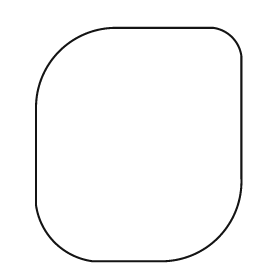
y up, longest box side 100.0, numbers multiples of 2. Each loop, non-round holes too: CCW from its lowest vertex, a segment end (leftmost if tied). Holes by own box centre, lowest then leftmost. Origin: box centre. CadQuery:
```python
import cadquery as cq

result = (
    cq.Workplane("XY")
    .moveTo(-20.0, -50.0)
    .lineTo(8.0, -50.0)
    .threePointArc((34.0, -40.0), (44.0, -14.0))
    .lineTo(44.0, 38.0)
    .threePointArc((40.0, 46.0), (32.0, 50.0))
    .lineTo(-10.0, 50.0)
    .threePointArc((-34.0, 40.0), (-44.0, 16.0))
    .lineTo(-44.0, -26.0)
    .threePointArc((-36.0, -42.0), (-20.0, -50.0))
    .close()
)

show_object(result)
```